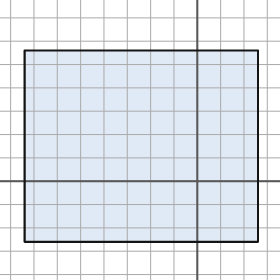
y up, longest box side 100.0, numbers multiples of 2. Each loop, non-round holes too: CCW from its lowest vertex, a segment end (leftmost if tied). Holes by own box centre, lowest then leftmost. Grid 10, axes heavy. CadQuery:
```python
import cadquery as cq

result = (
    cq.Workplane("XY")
    .moveTo(-74.0, -26.0)
    .lineTo(26.0, -26.0)
    .lineTo(26.0, 56.0)
    .lineTo(-74.0, 56.0)
    .close()
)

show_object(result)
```